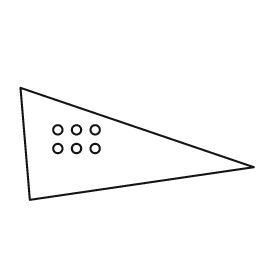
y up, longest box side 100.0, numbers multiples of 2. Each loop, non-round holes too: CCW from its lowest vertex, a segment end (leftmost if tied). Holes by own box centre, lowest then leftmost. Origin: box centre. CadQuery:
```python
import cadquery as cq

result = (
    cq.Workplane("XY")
    .moveTo(-46.0, -24.0)
    .lineTo(50.0, -10.0)
    .lineTo(-50.0, 24.0)
    .close()
    .moveTo(-34.0, -2.0)
    .circle(2.0)
    .moveTo(-26.0, -2.0)
    .circle(2.0)
    .moveTo(-18.0, -2.0)
    .circle(2.0)
    .moveTo(-34.0, 6.0)
    .circle(2.0)
    .moveTo(-26.0, 6.0)
    .circle(2.0)
    .moveTo(-18.0, 6.0)
    .circle(2.0)
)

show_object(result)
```